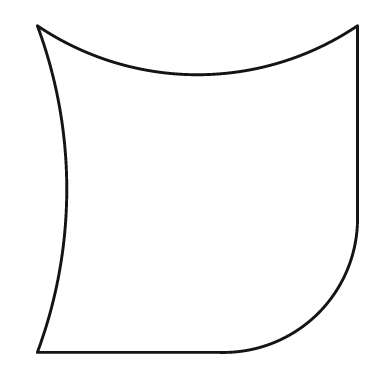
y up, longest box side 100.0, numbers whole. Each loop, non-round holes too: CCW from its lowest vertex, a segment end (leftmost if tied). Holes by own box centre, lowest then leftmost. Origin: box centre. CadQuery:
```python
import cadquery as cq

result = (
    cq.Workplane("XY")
    .moveTo(-49.0, -50.0)
    .lineTo(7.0, -50.0)
    .threePointArc((37.0, -38.0), (49.0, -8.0))
    .lineTo(49.0, 50.0)
    .threePointArc((0.0, 35.0), (-49.0, 50.0))
    .threePointArc((-40.0, 0.0), (-49.0, -50.0))
    .close()
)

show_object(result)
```